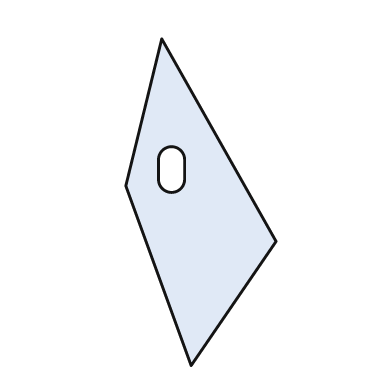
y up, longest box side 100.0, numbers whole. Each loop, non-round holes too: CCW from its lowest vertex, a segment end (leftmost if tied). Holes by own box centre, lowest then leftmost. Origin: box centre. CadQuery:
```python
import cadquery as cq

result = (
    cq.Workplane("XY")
    .moveTo(-3.0, -50.0)
    .lineTo(23.0, -12.0)
    .lineTo(-12.0, 50.0)
    .lineTo(-23.0, 5.0)
    .close()
    .moveTo(-13.0, 7.0)
    .threePointArc((-9.0, 3.0), (-5.0, 7.0))
    .lineTo(-5.0, 13.0)
    .threePointArc((-9.0, 17.0), (-13.0, 13.0))
    .close()
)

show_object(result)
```